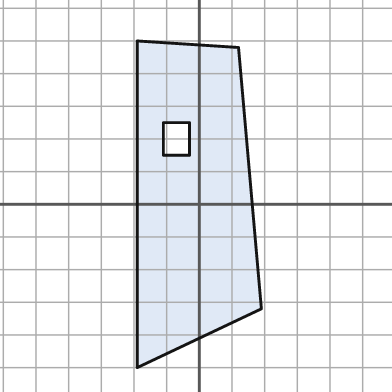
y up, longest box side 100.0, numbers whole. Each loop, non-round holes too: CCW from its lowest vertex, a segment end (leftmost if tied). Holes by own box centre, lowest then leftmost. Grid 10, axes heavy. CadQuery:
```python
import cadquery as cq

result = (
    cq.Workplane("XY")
    .moveTo(-19.0, -50.0)
    .lineTo(19.0, -32.0)
    .lineTo(12.0, 48.0)
    .lineTo(-19.0, 50.0)
    .close()
    .moveTo(-11.0, 15.0)
    .lineTo(-3.0, 15.0)
    .lineTo(-3.0, 25.0)
    .lineTo(-11.0, 25.0)
    .close()
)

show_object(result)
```